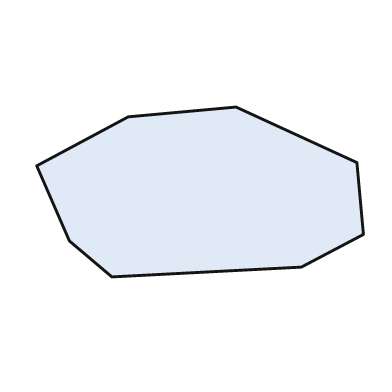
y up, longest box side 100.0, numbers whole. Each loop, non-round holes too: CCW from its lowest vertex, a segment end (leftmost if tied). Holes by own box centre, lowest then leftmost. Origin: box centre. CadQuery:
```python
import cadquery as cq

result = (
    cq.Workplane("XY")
    .moveTo(-27.0, -26.0)
    .lineTo(31.0, -23.0)
    .lineTo(50.0, -13.0)
    .lineTo(48.0, 9.0)
    .lineTo(11.0, 26.0)
    .lineTo(-22.0, 23.0)
    .lineTo(-50.0, 8.0)
    .lineTo(-40.0, -15.0)
    .close()
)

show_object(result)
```